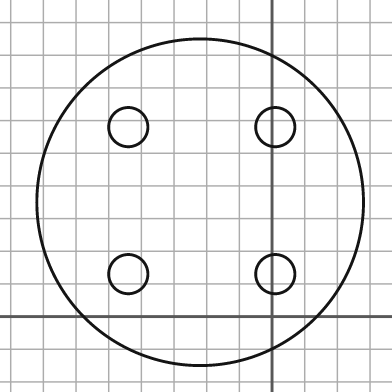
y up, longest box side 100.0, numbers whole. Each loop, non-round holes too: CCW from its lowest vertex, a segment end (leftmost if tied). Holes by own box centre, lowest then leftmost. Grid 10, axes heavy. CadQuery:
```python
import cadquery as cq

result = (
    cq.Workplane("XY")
    .moveTo(-22.0, 35.0)
    .circle(50.0)
    .moveTo(-44.0, 13.0)
    .circle(6.0)
    .moveTo(1.0, 13.0)
    .circle(6.0)
    .moveTo(-44.0, 58.0)
    .circle(6.0)
    .moveTo(1.0, 58.0)
    .circle(6.0)
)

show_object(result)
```